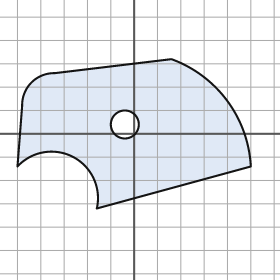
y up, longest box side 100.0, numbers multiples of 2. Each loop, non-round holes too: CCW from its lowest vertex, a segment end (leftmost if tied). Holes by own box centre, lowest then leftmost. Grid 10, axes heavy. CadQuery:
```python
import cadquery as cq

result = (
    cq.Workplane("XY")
    .moveTo(-16.0, -32.0)
    .lineTo(50.0, -14.0)
    .threePointArc((40.0, 14.0), (16.0, 32.0))
    .lineTo(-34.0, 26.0)
    .threePointArc((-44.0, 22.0), (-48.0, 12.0))
    .lineTo(-50.0, -14.0)
    .threePointArc((-26.0, -10.0), (-16.0, -32.0))
    .close()
    .moveTo(-4.0, 4.0)
    .circle(6.0)
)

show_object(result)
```